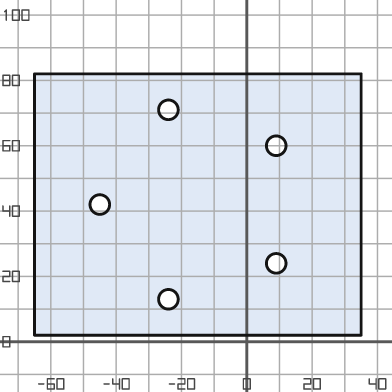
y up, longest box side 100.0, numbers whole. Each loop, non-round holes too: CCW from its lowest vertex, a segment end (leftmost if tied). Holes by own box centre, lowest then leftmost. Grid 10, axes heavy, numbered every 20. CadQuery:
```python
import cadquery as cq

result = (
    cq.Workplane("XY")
    .moveTo(-65.0, 2.0)
    .lineTo(35.0, 2.0)
    .lineTo(35.0, 82.0)
    .lineTo(-65.0, 82.0)
    .close()
    .moveTo(-24.0, 13.0)
    .circle(3.0)
    .moveTo(9.0, 24.0)
    .circle(3.0)
    .moveTo(-45.0, 42.0)
    .circle(3.0)
    .moveTo(9.0, 60.0)
    .circle(3.0)
    .moveTo(-24.0, 71.0)
    .circle(3.0)
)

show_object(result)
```